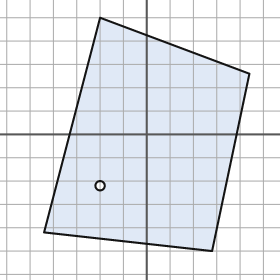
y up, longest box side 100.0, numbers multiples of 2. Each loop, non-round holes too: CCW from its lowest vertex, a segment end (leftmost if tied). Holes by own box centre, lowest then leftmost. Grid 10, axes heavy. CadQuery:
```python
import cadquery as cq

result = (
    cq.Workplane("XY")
    .moveTo(28.0, -50.0)
    .lineTo(44.0, 26.0)
    .lineTo(-20.0, 50.0)
    .lineTo(-44.0, -42.0)
    .close()
    .moveTo(-20.0, -22.0)
    .circle(2.0)
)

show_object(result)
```